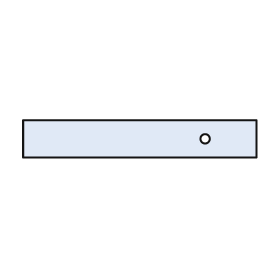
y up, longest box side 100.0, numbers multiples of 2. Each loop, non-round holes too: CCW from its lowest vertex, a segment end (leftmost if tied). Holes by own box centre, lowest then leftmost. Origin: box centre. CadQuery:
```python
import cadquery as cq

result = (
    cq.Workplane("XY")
    .moveTo(-50.0, -8.0)
    .lineTo(50.0, -8.0)
    .lineTo(50.0, 8.0)
    .lineTo(-50.0, 8.0)
    .close()
    .moveTo(28.0, 0.0)
    .circle(2.0)
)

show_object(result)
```